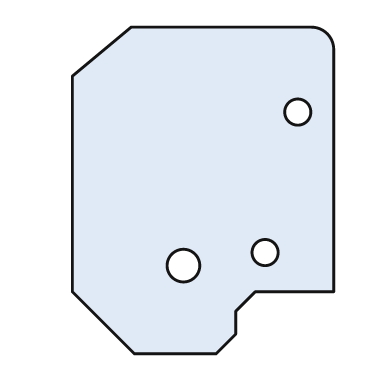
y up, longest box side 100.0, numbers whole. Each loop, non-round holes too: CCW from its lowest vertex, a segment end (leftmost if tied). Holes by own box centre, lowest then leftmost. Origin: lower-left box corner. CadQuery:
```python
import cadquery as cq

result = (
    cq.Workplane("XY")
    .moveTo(19.0, 0.0)
    .lineTo(44.0, 0.0)
    .lineTo(50.0, 6.0)
    .lineTo(50.0, 13.0)
    .lineTo(56.0, 19.0)
    .lineTo(80.0, 19.0)
    .lineTo(80.0, 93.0)
    .threePointArc((78.0, 98.0), (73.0, 100.0))
    .lineTo(18.0, 100.0)
    .lineTo(0.0, 85.0)
    .lineTo(0.0, 19.0)
    .close()
    .moveTo(34.0, 27.0)
    .circle(5.0)
    .moveTo(59.0, 31.0)
    .circle(4.0)
    .moveTo(69.0, 74.0)
    .circle(4.0)
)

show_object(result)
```